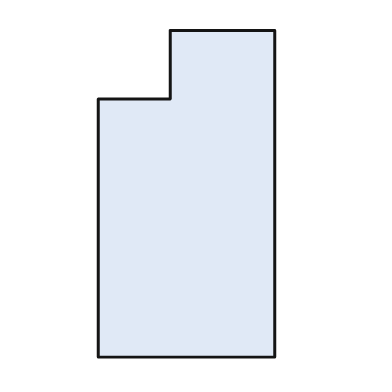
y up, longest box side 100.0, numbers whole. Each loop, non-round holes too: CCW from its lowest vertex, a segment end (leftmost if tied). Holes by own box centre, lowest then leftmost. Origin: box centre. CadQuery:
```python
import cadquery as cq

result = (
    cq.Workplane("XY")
    .moveTo(-27.0, -50.0)
    .lineTo(27.0, -50.0)
    .lineTo(27.0, 50.0)
    .lineTo(-5.0, 50.0)
    .lineTo(-5.0, 29.0)
    .lineTo(-27.0, 29.0)
    .close()
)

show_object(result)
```